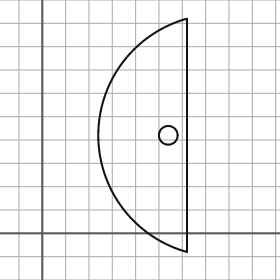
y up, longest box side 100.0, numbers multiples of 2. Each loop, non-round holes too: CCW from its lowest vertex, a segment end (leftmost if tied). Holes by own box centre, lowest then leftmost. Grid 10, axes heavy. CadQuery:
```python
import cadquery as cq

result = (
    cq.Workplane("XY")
    .moveTo(62.0, -8.0)
    .lineTo(62.0, 92.0)
    .threePointArc((24.0, 42.0), (62.0, -8.0))
    .close()
    .moveTo(54.0, 42.0)
    .circle(4.0)
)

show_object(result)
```